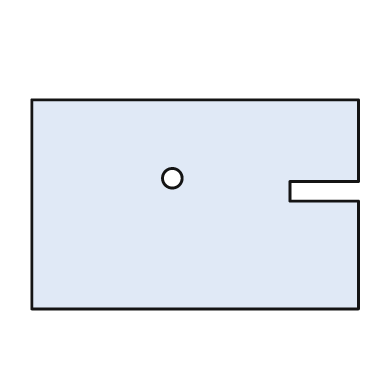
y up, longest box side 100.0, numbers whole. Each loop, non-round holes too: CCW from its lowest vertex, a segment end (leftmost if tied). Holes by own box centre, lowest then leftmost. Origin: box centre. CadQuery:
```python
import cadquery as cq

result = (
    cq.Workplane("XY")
    .moveTo(-50.0, -32.0)
    .lineTo(50.0, -32.0)
    .lineTo(50.0, 1.0)
    .lineTo(29.0, 1.0)
    .lineTo(29.0, 7.0)
    .lineTo(50.0, 7.0)
    .lineTo(50.0, 32.0)
    .lineTo(-50.0, 32.0)
    .close()
    .moveTo(-7.0, 8.0)
    .circle(3.0)
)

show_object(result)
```